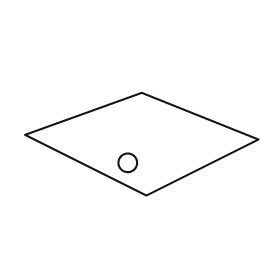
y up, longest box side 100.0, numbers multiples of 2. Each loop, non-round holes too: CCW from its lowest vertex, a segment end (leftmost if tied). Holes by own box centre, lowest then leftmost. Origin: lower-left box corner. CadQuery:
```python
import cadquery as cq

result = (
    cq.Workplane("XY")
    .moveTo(52.0, 0.0)
    .lineTo(100.0, 24.0)
    .lineTo(50.0, 44.0)
    .lineTo(0.0, 26.0)
    .close()
    .moveTo(44.0, 14.0)
    .circle(4.0)
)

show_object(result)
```